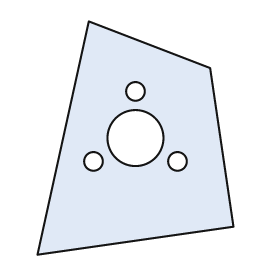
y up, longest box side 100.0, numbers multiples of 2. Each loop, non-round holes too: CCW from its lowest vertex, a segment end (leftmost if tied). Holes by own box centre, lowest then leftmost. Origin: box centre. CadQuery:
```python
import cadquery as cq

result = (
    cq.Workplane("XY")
    .moveTo(-42.0, -50.0)
    .lineTo(42.0, -38.0)
    .lineTo(32.0, 30.0)
    .lineTo(-20.0, 50.0)
    .close()
    .moveTo(-18.0, -10.0)
    .circle(4.0)
    .moveTo(18.0, -10.0)
    .circle(4.0)
    .moveTo(0.0, 0.0)
    .circle(12.0)
    .moveTo(0.0, 20.0)
    .circle(4.0)
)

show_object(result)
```